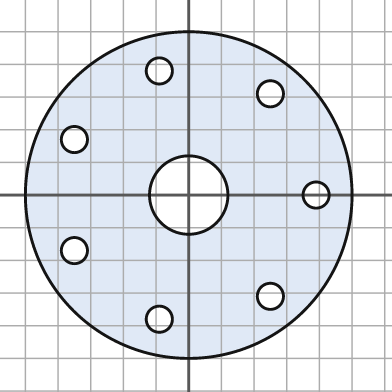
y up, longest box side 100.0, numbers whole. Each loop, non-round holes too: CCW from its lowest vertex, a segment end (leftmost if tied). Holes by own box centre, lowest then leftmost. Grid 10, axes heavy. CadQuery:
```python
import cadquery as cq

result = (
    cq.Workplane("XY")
    .moveTo(0.0, 0.0)
    .circle(50.0)
    .moveTo(-9.0, -38.0)
    .circle(4.0)
    .moveTo(25.0, -31.0)
    .circle(4.0)
    .moveTo(-35.0, -17.0)
    .circle(4.0)
    .moveTo(0.0, 0.0)
    .circle(12.0)
    .moveTo(39.0, 0.0)
    .circle(4.0)
    .moveTo(-35.0, 17.0)
    .circle(4.0)
    .moveTo(25.0, 31.0)
    .circle(4.0)
    .moveTo(-9.0, 38.0)
    .circle(4.0)
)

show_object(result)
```